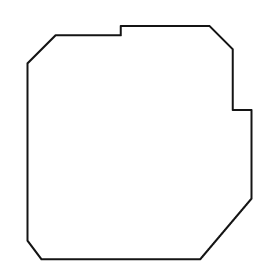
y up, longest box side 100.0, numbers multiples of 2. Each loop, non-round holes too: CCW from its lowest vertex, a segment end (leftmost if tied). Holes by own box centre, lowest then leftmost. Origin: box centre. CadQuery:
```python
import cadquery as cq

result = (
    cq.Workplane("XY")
    .moveTo(-42.0, -50.0)
    .lineTo(26.0, -50.0)
    .lineTo(48.0, -24.0)
    .lineTo(48.0, 14.0)
    .lineTo(40.0, 14.0)
    .lineTo(40.0, 40.0)
    .lineTo(30.0, 50.0)
    .lineTo(-8.0, 50.0)
    .lineTo(-8.0, 46.0)
    .lineTo(-36.0, 46.0)
    .lineTo(-48.0, 34.0)
    .lineTo(-48.0, -42.0)
    .close()
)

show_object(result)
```